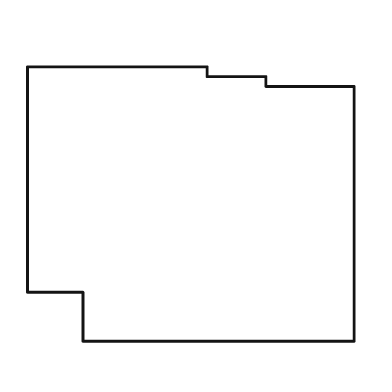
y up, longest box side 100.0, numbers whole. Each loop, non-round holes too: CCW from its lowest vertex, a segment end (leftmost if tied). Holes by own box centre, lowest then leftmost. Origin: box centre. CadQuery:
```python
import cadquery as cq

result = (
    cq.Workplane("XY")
    .moveTo(-33.0, -42.0)
    .lineTo(50.0, -42.0)
    .lineTo(50.0, 36.0)
    .lineTo(23.0, 36.0)
    .lineTo(23.0, 39.0)
    .lineTo(5.0, 39.0)
    .lineTo(5.0, 42.0)
    .lineTo(-50.0, 42.0)
    .lineTo(-50.0, -27.0)
    .lineTo(-33.0, -27.0)
    .close()
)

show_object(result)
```